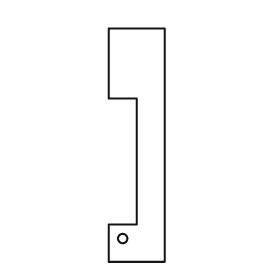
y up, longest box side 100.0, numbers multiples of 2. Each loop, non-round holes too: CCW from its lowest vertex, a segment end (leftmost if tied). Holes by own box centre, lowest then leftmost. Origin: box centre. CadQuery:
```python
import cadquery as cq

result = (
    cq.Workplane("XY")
    .moveTo(-12.0, -50.0)
    .lineTo(12.0, -50.0)
    .lineTo(12.0, 50.0)
    .lineTo(-12.0, 50.0)
    .lineTo(-12.0, 20.0)
    .lineTo(0.0, 20.0)
    .lineTo(0.0, -34.0)
    .lineTo(-12.0, -34.0)
    .close()
    .moveTo(-6.0, -40.0)
    .circle(2.0)
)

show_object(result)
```